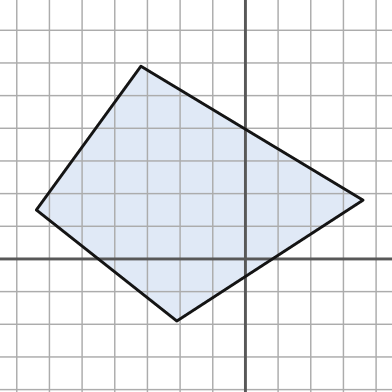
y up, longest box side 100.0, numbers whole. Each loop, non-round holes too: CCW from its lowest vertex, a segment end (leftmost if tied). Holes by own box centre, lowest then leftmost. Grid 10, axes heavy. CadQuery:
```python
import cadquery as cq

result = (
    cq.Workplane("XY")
    .moveTo(-21.0, -19.0)
    .lineTo(36.0, 18.0)
    .lineTo(-32.0, 59.0)
    .lineTo(-64.0, 15.0)
    .close()
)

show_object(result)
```